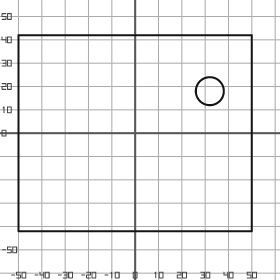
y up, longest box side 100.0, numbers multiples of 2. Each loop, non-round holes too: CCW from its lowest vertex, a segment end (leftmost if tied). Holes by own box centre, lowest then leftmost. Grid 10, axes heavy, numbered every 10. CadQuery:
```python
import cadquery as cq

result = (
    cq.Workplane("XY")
    .moveTo(-50.0, -42.0)
    .lineTo(50.0, -42.0)
    .lineTo(50.0, 42.0)
    .lineTo(-50.0, 42.0)
    .close()
    .moveTo(32.0, 18.0)
    .circle(6.0)
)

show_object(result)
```